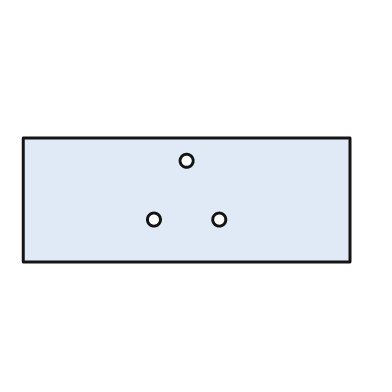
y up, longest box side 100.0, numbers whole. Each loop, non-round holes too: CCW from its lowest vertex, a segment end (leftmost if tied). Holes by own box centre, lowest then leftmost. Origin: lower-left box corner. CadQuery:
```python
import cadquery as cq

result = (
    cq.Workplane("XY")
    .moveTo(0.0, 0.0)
    .lineTo(100.0, 0.0)
    .lineTo(100.0, 38.0)
    .lineTo(0.0, 38.0)
    .close()
    .moveTo(40.0, 13.0)
    .circle(2.0)
    .moveTo(60.0, 13.0)
    .circle(2.0)
    .moveTo(50.0, 31.0)
    .circle(2.0)
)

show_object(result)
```